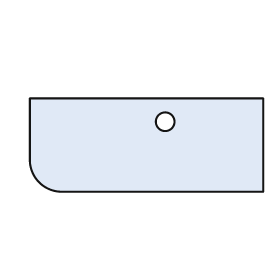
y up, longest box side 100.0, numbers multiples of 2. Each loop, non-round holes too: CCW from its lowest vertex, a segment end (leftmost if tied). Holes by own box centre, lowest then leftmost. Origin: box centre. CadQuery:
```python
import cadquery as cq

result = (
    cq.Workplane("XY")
    .moveTo(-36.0, -20.0)
    .lineTo(50.0, -20.0)
    .lineTo(50.0, 20.0)
    .lineTo(-50.0, 20.0)
    .lineTo(-50.0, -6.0)
    .threePointArc((-46.0, -16.0), (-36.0, -20.0))
    .close()
    .moveTo(8.0, 10.0)
    .circle(4.0)
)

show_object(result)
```